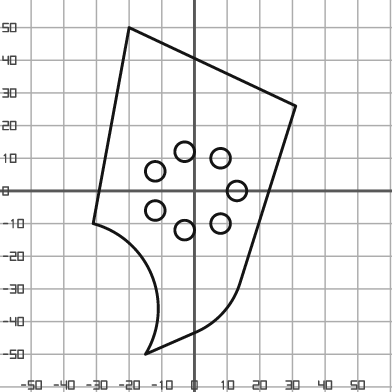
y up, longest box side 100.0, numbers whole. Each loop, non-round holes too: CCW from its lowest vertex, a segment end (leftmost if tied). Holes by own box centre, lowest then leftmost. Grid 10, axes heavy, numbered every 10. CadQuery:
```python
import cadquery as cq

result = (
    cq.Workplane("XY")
    .moveTo(-15.0, -50.0)
    .lineTo(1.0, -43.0)
    .threePointArc((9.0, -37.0), (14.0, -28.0))
    .lineTo(31.0, 26.0)
    .lineTo(-20.0, 50.0)
    .lineTo(-31.0, -10.0)
    .threePointArc((-13.0, -26.0), (-15.0, -50.0))
    .close()
    .moveTo(-3.0, -12.0)
    .circle(3.0)
    .moveTo(8.0, -10.0)
    .circle(3.0)
    .moveTo(-12.0, -6.0)
    .circle(3.0)
    .moveTo(13.0, 0.0)
    .circle(3.0)
    .moveTo(-12.0, 6.0)
    .circle(3.0)
    .moveTo(8.0, 10.0)
    .circle(3.0)
    .moveTo(-3.0, 12.0)
    .circle(3.0)
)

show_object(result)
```